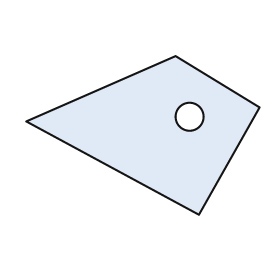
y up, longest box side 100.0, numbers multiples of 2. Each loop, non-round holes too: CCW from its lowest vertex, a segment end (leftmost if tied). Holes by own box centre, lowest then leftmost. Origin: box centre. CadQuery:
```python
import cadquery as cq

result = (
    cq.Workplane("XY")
    .moveTo(24.0, -34.0)
    .lineTo(50.0, 12.0)
    .lineTo(14.0, 34.0)
    .lineTo(-50.0, 6.0)
    .close()
    .moveTo(20.0, 8.0)
    .circle(6.0)
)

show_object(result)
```